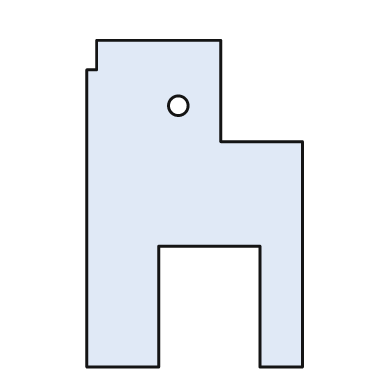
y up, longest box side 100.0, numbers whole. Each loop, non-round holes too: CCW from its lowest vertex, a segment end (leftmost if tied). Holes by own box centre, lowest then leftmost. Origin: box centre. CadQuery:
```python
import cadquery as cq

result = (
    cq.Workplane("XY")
    .moveTo(-33.0, -50.0)
    .lineTo(-11.0, -50.0)
    .lineTo(-11.0, -13.0)
    .lineTo(20.0, -13.0)
    .lineTo(20.0, -50.0)
    .lineTo(33.0, -50.0)
    .lineTo(33.0, 19.0)
    .lineTo(8.0, 19.0)
    .lineTo(8.0, 50.0)
    .lineTo(-30.0, 50.0)
    .lineTo(-30.0, 41.0)
    .lineTo(-33.0, 41.0)
    .close()
    .moveTo(-5.0, 30.0)
    .circle(3.0)
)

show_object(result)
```